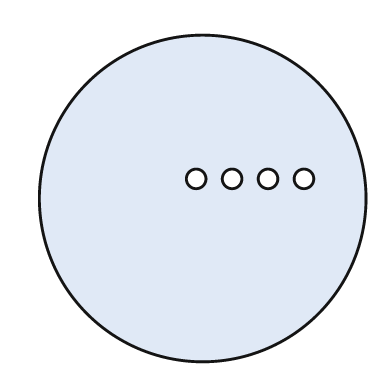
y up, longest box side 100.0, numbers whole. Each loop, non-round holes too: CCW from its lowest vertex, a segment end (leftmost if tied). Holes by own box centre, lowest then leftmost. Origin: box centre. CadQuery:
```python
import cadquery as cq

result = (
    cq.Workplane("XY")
    .moveTo(0.0, 0.0)
    .circle(50.0)
    .moveTo(-2.0, 6.0)
    .circle(3.0)
    .moveTo(9.0, 6.0)
    .circle(3.0)
    .moveTo(20.0, 6.0)
    .circle(3.0)
    .moveTo(31.0, 6.0)
    .circle(3.0)
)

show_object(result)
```